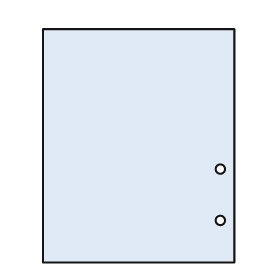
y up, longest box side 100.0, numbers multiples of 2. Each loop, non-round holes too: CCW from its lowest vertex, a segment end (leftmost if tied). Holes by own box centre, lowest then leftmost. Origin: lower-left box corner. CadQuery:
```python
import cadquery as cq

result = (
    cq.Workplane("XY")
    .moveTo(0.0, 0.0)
    .lineTo(82.0, 0.0)
    .lineTo(82.0, 100.0)
    .lineTo(0.0, 100.0)
    .close()
    .moveTo(76.0, 18.0)
    .circle(2.0)
    .moveTo(76.0, 40.0)
    .circle(2.0)
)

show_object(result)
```